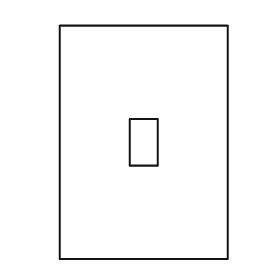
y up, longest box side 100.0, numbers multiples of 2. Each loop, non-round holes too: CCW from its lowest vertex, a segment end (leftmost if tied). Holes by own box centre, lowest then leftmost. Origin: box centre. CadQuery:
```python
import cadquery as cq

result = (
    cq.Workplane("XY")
    .moveTo(-36.0, -50.0)
    .lineTo(36.0, -50.0)
    .lineTo(36.0, 50.0)
    .lineTo(-36.0, 50.0)
    .close()
    .moveTo(-6.0, -10.0)
    .lineTo(6.0, -10.0)
    .lineTo(6.0, 10.0)
    .lineTo(-6.0, 10.0)
    .close()
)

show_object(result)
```